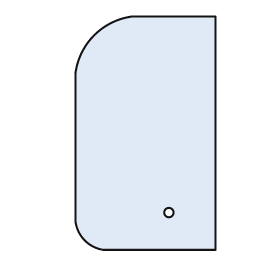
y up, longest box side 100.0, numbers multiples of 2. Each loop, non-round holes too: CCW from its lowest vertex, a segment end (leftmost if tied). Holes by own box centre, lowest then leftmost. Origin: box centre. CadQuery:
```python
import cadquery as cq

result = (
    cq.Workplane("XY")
    .moveTo(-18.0, -50.0)
    .lineTo(30.0, -50.0)
    .lineTo(30.0, 50.0)
    .lineTo(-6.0, 50.0)
    .threePointArc((-22.0, 42.0), (-30.0, 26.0))
    .lineTo(-30.0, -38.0)
    .threePointArc((-26.0, -46.0), (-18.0, -50.0))
    .close()
    .moveTo(10.0, -34.0)
    .circle(2.0)
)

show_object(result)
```